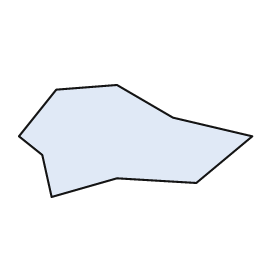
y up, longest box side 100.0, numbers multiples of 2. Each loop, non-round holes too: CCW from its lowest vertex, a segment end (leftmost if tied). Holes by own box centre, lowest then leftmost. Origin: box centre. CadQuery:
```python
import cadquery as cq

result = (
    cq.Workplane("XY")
    .moveTo(-36.0, -24.0)
    .lineTo(-8.0, -16.0)
    .lineTo(26.0, -18.0)
    .lineTo(50.0, 2.0)
    .lineTo(16.0, 10.0)
    .lineTo(-8.0, 24.0)
    .lineTo(-34.0, 22.0)
    .lineTo(-50.0, 2.0)
    .lineTo(-40.0, -6.0)
    .close()
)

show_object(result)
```